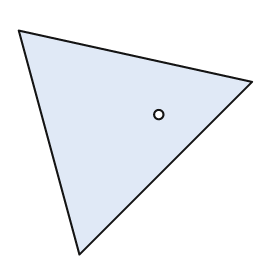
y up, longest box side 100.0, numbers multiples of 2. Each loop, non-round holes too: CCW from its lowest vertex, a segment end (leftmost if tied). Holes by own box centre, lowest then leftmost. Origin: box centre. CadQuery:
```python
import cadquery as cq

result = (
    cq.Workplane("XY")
    .moveTo(-24.0, -48.0)
    .lineTo(50.0, 26.0)
    .lineTo(-50.0, 48.0)
    .close()
    .moveTo(10.0, 12.0)
    .circle(2.0)
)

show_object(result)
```